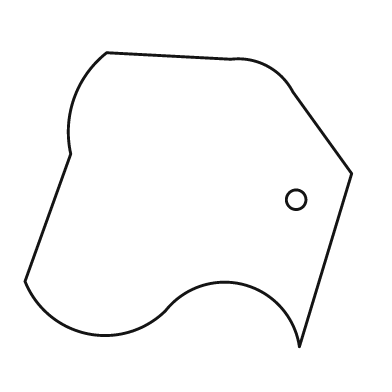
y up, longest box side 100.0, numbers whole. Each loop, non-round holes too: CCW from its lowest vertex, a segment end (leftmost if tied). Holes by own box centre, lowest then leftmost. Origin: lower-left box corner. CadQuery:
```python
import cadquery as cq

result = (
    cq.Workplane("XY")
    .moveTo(84.0, 0.0)
    .lineTo(100.0, 53.0)
    .lineTo(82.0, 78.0)
    .threePointArc((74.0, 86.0), (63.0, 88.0))
    .lineTo(25.0, 90.0)
    .threePointArc((15.0, 76.0), (14.0, 59.0))
    .lineTo(0.0, 20.0)
    .threePointArc((19.0, 4.0), (43.0, 11.0))
    .threePointArc((67.0, 19.0), (84.0, 0.0))
    .close()
    .moveTo(83.0, 45.0)
    .circle(3.0)
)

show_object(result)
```